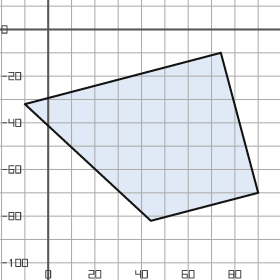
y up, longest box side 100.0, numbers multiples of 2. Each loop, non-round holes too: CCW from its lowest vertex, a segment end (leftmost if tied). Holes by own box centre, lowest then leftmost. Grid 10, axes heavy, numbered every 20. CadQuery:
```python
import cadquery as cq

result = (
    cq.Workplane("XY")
    .moveTo(44.0, -82.0)
    .lineTo(90.0, -70.0)
    .lineTo(74.0, -10.0)
    .lineTo(-10.0, -32.0)
    .close()
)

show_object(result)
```